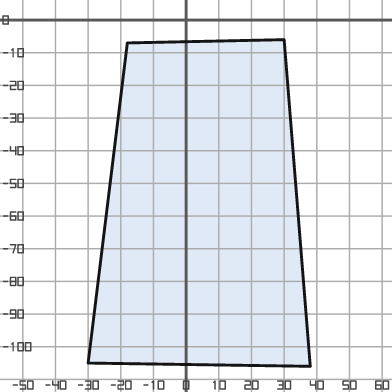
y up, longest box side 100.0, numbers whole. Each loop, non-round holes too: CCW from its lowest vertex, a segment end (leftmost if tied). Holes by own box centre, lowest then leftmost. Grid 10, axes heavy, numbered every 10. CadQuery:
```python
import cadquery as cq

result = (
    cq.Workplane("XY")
    .moveTo(38.0, -106.0)
    .lineTo(30.0, -6.0)
    .lineTo(-18.0, -7.0)
    .lineTo(-30.0, -105.0)
    .close()
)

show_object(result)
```